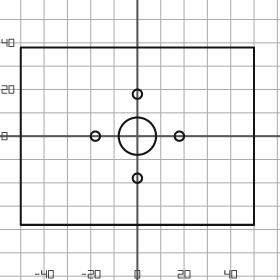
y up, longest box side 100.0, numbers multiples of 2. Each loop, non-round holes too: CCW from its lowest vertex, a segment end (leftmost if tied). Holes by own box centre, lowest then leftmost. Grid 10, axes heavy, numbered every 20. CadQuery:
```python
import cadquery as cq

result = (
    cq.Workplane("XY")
    .moveTo(-50.0, -38.0)
    .lineTo(50.0, -38.0)
    .lineTo(50.0, 38.0)
    .lineTo(-50.0, 38.0)
    .close()
    .moveTo(0.0, -18.0)
    .circle(2.0)
    .moveTo(-18.0, 0.0)
    .circle(2.0)
    .moveTo(0.0, 0.0)
    .circle(8.0)
    .moveTo(18.0, 0.0)
    .circle(2.0)
    .moveTo(0.0, 18.0)
    .circle(2.0)
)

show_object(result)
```